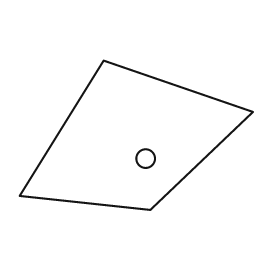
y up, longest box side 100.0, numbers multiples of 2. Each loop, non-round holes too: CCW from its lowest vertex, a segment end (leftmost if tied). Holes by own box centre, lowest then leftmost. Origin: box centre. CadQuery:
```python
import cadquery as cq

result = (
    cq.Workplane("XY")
    .moveTo(6.0, -32.0)
    .lineTo(50.0, 10.0)
    .lineTo(-14.0, 32.0)
    .lineTo(-50.0, -26.0)
    .close()
    .moveTo(4.0, -10.0)
    .circle(4.0)
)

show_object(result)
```